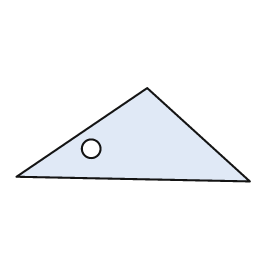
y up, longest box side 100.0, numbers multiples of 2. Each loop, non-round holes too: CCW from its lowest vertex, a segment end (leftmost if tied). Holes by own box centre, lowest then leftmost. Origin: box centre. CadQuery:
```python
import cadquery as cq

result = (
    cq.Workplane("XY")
    .moveTo(50.0, -20.0)
    .lineTo(6.0, 20.0)
    .lineTo(-50.0, -18.0)
    .close()
    .moveTo(-18.0, -6.0)
    .circle(4.0)
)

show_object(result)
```